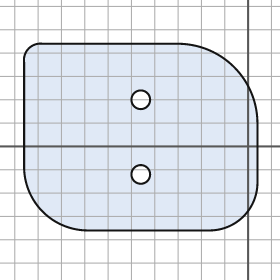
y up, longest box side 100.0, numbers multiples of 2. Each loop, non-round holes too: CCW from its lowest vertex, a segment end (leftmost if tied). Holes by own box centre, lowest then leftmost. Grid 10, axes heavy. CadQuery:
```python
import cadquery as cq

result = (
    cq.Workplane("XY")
    .moveTo(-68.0, -36.0)
    .lineTo(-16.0, -36.0)
    .threePointArc((-2.0, -30.0), (4.0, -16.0))
    .lineTo(4.0, 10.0)
    .threePointArc((-6.0, 34.0), (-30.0, 44.0))
    .lineTo(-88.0, 44.0)
    .threePointArc((-94.0, 42.0), (-96.0, 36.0))
    .lineTo(-96.0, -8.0)
    .threePointArc((-88.0, -28.0), (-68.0, -36.0))
    .close()
    .moveTo(-46.0, -12.0)
    .circle(4.0)
    .moveTo(-46.0, 20.0)
    .circle(4.0)
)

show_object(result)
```